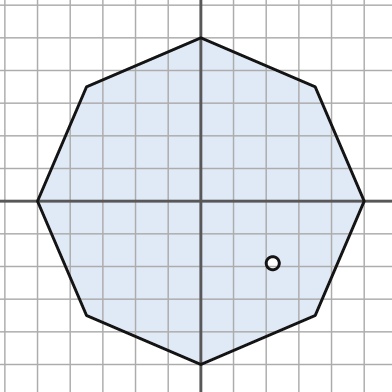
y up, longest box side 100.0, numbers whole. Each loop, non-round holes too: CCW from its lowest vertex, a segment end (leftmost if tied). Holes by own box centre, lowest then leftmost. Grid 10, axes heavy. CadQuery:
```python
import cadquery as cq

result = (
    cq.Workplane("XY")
    .moveTo(0.0, -50.0)
    .lineTo(35.0, -35.0)
    .lineTo(50.0, 0.0)
    .lineTo(35.0, 35.0)
    .lineTo(0.0, 50.0)
    .lineTo(-35.0, 35.0)
    .lineTo(-50.0, 0.0)
    .lineTo(-35.0, -35.0)
    .close()
    .moveTo(22.0, -19.0)
    .circle(2.0)
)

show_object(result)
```